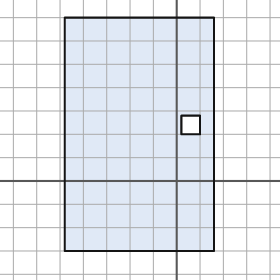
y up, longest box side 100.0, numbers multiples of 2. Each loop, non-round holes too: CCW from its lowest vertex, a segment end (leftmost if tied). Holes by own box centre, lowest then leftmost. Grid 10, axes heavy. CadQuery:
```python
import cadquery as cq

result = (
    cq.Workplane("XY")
    .moveTo(-48.0, -30.0)
    .lineTo(16.0, -30.0)
    .lineTo(16.0, 70.0)
    .lineTo(-48.0, 70.0)
    .close()
    .moveTo(2.0, 20.0)
    .lineTo(10.0, 20.0)
    .lineTo(10.0, 28.0)
    .lineTo(2.0, 28.0)
    .close()
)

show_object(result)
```